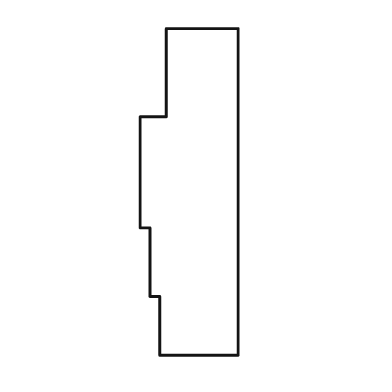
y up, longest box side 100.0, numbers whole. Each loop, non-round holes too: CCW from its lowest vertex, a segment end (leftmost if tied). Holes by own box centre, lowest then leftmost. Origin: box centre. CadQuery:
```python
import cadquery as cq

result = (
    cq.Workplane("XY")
    .moveTo(-9.0, -50.0)
    .lineTo(15.0, -50.0)
    .lineTo(15.0, 50.0)
    .lineTo(-7.0, 50.0)
    .lineTo(-7.0, 23.0)
    .lineTo(-15.0, 23.0)
    .lineTo(-15.0, -11.0)
    .lineTo(-12.0, -11.0)
    .lineTo(-12.0, -32.0)
    .lineTo(-9.0, -32.0)
    .close()
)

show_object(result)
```